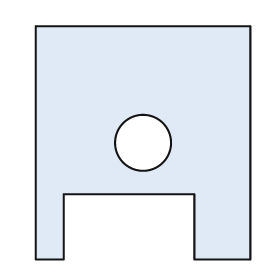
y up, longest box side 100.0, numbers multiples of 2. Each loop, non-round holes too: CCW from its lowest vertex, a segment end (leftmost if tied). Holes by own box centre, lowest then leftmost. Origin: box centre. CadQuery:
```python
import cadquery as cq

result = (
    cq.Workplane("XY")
    .moveTo(-46.0, -50.0)
    .lineTo(-34.0, -50.0)
    .lineTo(-34.0, -22.0)
    .lineTo(22.0, -22.0)
    .lineTo(22.0, -50.0)
    .lineTo(46.0, -50.0)
    .lineTo(46.0, 50.0)
    .lineTo(-46.0, 50.0)
    .close()
    .moveTo(0.0, 0.0)
    .circle(12.0)
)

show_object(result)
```